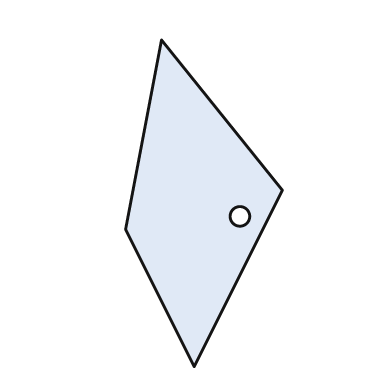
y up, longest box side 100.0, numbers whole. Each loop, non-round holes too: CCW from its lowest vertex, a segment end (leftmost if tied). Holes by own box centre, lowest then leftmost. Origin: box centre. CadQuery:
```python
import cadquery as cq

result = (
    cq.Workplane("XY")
    .moveTo(-3.0, -50.0)
    .lineTo(24.0, 4.0)
    .lineTo(-13.0, 50.0)
    .lineTo(-24.0, -8.0)
    .close()
    .moveTo(11.0, -4.0)
    .circle(3.0)
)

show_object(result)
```